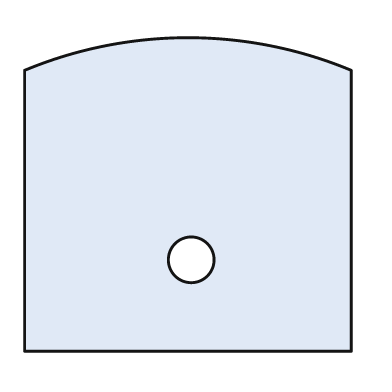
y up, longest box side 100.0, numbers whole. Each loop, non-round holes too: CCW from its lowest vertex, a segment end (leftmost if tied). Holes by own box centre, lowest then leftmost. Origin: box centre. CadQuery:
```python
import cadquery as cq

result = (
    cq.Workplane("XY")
    .moveTo(-50.0, -48.0)
    .lineTo(50.0, -48.0)
    .lineTo(50.0, 38.0)
    .threePointArc((0.0, 48.0), (-50.0, 38.0))
    .close()
    .moveTo(1.0, -20.0)
    .circle(7.0)
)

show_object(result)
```